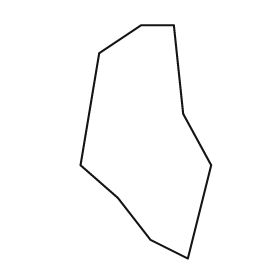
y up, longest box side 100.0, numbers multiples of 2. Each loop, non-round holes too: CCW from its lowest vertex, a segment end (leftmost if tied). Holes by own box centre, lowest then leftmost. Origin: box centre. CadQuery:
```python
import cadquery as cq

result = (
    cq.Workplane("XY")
    .moveTo(18.0, -50.0)
    .lineTo(28.0, -10.0)
    .lineTo(16.0, 12.0)
    .lineTo(12.0, 50.0)
    .lineTo(-2.0, 50.0)
    .lineTo(-20.0, 38.0)
    .lineTo(-28.0, -10.0)
    .lineTo(-12.0, -24.0)
    .lineTo(2.0, -42.0)
    .close()
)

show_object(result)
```